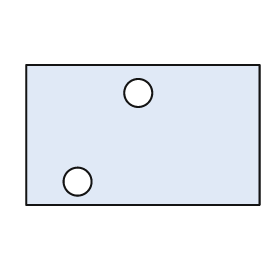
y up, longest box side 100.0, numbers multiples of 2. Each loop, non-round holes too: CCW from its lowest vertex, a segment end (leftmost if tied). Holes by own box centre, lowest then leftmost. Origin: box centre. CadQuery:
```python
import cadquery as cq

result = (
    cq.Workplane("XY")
    .moveTo(-50.0, -30.0)
    .lineTo(50.0, -30.0)
    .lineTo(50.0, 30.0)
    .lineTo(-50.0, 30.0)
    .close()
    .moveTo(-28.0, -20.0)
    .circle(6.0)
    .moveTo(-2.0, 18.0)
    .circle(6.0)
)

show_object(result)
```